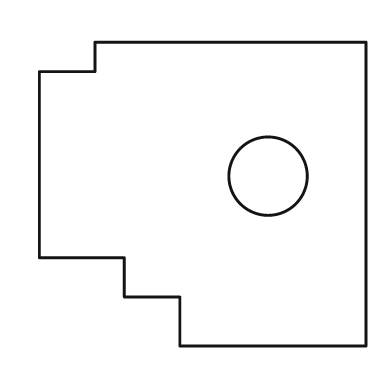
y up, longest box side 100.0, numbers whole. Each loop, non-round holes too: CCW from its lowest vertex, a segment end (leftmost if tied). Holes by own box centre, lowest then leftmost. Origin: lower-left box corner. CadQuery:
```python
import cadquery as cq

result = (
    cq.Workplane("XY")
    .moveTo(43.0, 0.0)
    .lineTo(100.0, 0.0)
    .lineTo(100.0, 93.0)
    .lineTo(17.0, 93.0)
    .lineTo(17.0, 84.0)
    .lineTo(0.0, 84.0)
    .lineTo(0.0, 27.0)
    .lineTo(26.0, 27.0)
    .lineTo(26.0, 15.0)
    .lineTo(43.0, 15.0)
    .close()
    .moveTo(70.0, 52.0)
    .circle(12.0)
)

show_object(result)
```